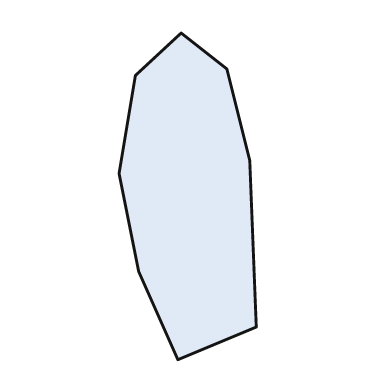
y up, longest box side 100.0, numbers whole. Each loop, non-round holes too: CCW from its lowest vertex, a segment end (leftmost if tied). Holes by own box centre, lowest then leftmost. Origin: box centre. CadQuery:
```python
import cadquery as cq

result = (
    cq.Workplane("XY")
    .moveTo(-3.0, -50.0)
    .lineTo(21.0, -40.0)
    .lineTo(19.0, 11.0)
    .lineTo(12.0, 39.0)
    .lineTo(-2.0, 50.0)
    .lineTo(-16.0, 37.0)
    .lineTo(-21.0, 7.0)
    .lineTo(-15.0, -23.0)
    .close()
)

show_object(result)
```